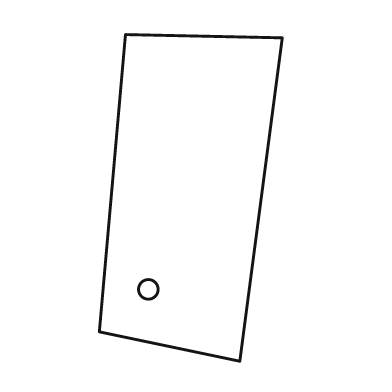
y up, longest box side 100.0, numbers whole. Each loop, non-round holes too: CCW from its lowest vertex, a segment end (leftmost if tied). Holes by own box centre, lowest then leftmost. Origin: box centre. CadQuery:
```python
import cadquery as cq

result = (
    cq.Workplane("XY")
    .moveTo(15.0, -50.0)
    .lineTo(28.0, 49.0)
    .lineTo(-20.0, 50.0)
    .lineTo(-28.0, -41.0)
    .close()
    .moveTo(-13.0, -28.0)
    .circle(3.0)
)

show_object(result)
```